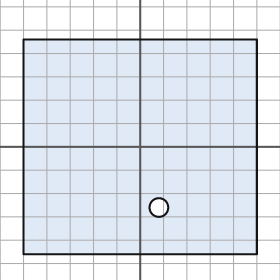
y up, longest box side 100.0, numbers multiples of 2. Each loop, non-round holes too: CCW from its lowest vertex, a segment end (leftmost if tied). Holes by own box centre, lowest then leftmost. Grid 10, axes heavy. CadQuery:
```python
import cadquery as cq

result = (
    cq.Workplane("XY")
    .moveTo(-50.0, -46.0)
    .lineTo(50.0, -46.0)
    .lineTo(50.0, 46.0)
    .lineTo(-50.0, 46.0)
    .close()
    .moveTo(8.0, -26.0)
    .circle(4.0)
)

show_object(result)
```